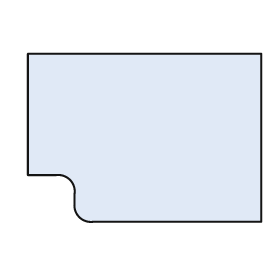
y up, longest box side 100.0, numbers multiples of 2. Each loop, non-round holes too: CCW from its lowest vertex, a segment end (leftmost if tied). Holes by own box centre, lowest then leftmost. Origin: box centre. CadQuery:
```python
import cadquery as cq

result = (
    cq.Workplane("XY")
    .moveTo(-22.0, -36.0)
    .lineTo(50.0, -36.0)
    .lineTo(50.0, 36.0)
    .lineTo(-50.0, 36.0)
    .lineTo(-50.0, -16.0)
    .lineTo(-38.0, -16.0)
    .threePointArc((-32.0, -18.0), (-30.0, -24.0))
    .lineTo(-30.0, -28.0)
    .threePointArc((-28.0, -34.0), (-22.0, -36.0))
    .close()
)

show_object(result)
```